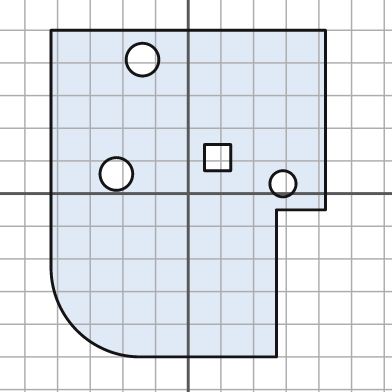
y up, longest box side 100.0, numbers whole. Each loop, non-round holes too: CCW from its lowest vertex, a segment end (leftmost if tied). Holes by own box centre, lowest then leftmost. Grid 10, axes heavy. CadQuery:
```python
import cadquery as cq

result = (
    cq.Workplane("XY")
    .moveTo(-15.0, -50.0)
    .lineTo(27.0, -50.0)
    .lineTo(27.0, -5.0)
    .lineTo(42.0, -5.0)
    .lineTo(42.0, 50.0)
    .lineTo(-42.0, 50.0)
    .lineTo(-42.0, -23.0)
    .threePointArc((-34.0, -42.0), (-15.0, -50.0))
    .close()
    .moveTo(29.0, 3.0)
    .circle(4.0)
    .moveTo(-22.0, 6.0)
    .circle(5.0)
    .moveTo(5.0, 7.0)
    .lineTo(13.0, 7.0)
    .lineTo(13.0, 15.0)
    .lineTo(5.0, 15.0)
    .close()
    .moveTo(-14.0, 41.0)
    .circle(5.0)
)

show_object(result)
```